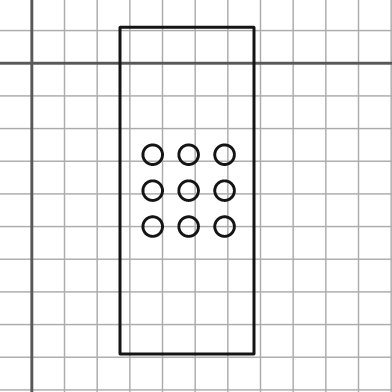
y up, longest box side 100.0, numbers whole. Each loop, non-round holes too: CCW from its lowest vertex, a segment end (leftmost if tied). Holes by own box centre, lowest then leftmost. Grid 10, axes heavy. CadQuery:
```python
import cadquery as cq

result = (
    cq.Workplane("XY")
    .moveTo(27.0, -89.0)
    .lineTo(68.0, -89.0)
    .lineTo(68.0, 11.0)
    .lineTo(27.0, 11.0)
    .close()
    .moveTo(37.0, -50.0)
    .circle(3.0)
    .moveTo(48.0, -50.0)
    .circle(3.0)
    .moveTo(59.0, -50.0)
    .circle(3.0)
    .moveTo(37.0, -39.0)
    .circle(3.0)
    .moveTo(48.0, -39.0)
    .circle(3.0)
    .moveTo(59.0, -39.0)
    .circle(3.0)
    .moveTo(37.0, -28.0)
    .circle(3.0)
    .moveTo(48.0, -28.0)
    .circle(3.0)
    .moveTo(59.0, -28.0)
    .circle(3.0)
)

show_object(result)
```